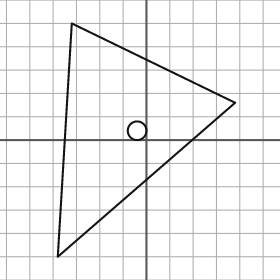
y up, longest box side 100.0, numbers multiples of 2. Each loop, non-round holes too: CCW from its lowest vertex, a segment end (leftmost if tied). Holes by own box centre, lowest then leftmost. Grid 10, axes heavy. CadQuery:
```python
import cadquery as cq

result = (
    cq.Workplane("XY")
    .moveTo(-38.0, -50.0)
    .lineTo(38.0, 16.0)
    .lineTo(-32.0, 50.0)
    .close()
    .moveTo(-4.0, 4.0)
    .circle(4.0)
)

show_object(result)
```